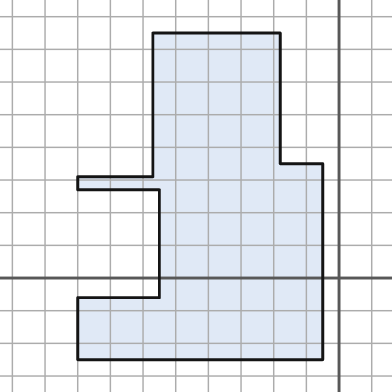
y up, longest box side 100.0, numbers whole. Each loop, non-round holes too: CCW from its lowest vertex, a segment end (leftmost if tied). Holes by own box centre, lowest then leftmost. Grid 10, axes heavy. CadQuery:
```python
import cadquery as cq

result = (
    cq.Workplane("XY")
    .moveTo(-80.0, -25.0)
    .lineTo(-5.0, -25.0)
    .lineTo(-5.0, 35.0)
    .lineTo(-18.0, 35.0)
    .lineTo(-18.0, 75.0)
    .lineTo(-57.0, 75.0)
    .lineTo(-57.0, 31.0)
    .lineTo(-80.0, 31.0)
    .lineTo(-80.0, 27.0)
    .lineTo(-55.0, 27.0)
    .lineTo(-55.0, -6.0)
    .lineTo(-80.0, -6.0)
    .close()
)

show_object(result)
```